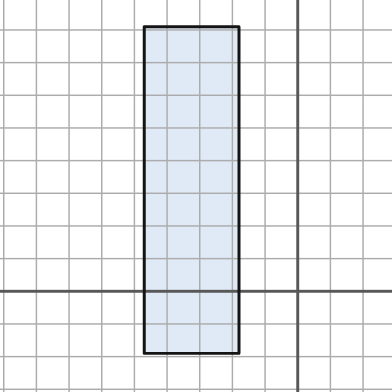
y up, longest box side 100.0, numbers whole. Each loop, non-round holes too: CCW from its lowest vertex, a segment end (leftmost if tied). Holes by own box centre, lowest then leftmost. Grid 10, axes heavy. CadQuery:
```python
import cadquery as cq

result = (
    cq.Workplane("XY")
    .moveTo(-47.0, -19.0)
    .lineTo(-18.0, -19.0)
    .lineTo(-18.0, 81.0)
    .lineTo(-47.0, 81.0)
    .close()
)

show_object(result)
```